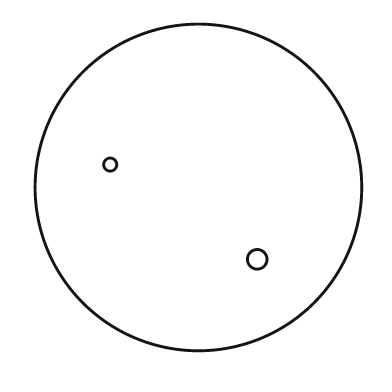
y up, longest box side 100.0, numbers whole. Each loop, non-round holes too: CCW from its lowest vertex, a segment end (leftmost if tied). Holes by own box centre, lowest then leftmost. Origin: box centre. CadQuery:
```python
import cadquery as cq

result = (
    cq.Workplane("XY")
    .moveTo(0.0, 0.0)
    .circle(50.0)
    .moveTo(18.0, -22.0)
    .circle(3.0)
    .moveTo(-27.0, 7.0)
    .circle(2.0)
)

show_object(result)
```